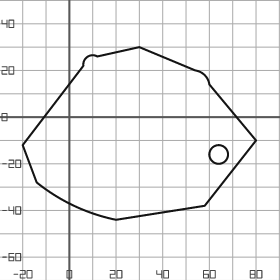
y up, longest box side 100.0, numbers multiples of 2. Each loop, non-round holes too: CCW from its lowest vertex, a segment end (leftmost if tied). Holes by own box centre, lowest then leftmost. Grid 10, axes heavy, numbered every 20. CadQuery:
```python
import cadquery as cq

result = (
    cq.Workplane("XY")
    .moveTo(20.0, -44.0)
    .lineTo(58.0, -38.0)
    .lineTo(80.0, -10.0)
    .lineTo(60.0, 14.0)
    .threePointArc((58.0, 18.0), (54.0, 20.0))
    .lineTo(30.0, 30.0)
    .lineTo(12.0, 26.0)
    .threePointArc((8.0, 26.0), (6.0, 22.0))
    .lineTo(-20.0, -12.0)
    .lineTo(-14.0, -28.0)
    .threePointArc((2.0, -38.0), (20.0, -44.0))
    .close()
    .moveTo(64.0, -16.0)
    .circle(4.0)
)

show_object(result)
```